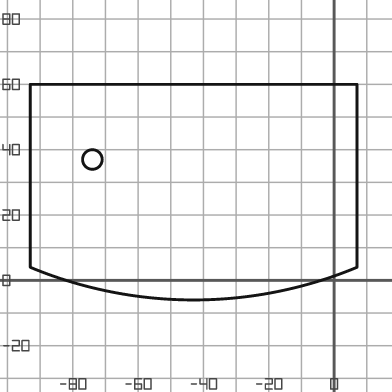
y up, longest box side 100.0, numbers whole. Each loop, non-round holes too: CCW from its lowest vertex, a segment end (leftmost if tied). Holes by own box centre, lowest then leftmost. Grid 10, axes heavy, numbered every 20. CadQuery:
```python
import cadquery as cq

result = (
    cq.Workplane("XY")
    .moveTo(-93.0, 4.0)
    .threePointArc((-43.0, -6.0), (7.0, 4.0))
    .lineTo(7.0, 60.0)
    .lineTo(-93.0, 60.0)
    .close()
    .moveTo(-74.0, 37.0)
    .circle(3.0)
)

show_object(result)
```